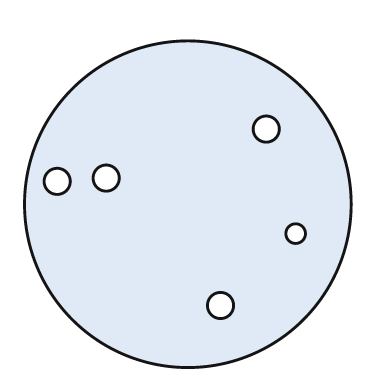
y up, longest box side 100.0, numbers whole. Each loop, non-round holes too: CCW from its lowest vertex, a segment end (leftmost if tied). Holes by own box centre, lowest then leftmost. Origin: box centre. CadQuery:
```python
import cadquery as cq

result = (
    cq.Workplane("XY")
    .moveTo(0.0, 0.0)
    .circle(50.0)
    .moveTo(10.0, -31.0)
    .circle(4.0)
    .moveTo(33.0, -9.0)
    .circle(3.0)
    .moveTo(-40.0, 7.0)
    .circle(4.0)
    .moveTo(-25.0, 8.0)
    .circle(4.0)
    .moveTo(24.0, 23.0)
    .circle(4.0)
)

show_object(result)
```